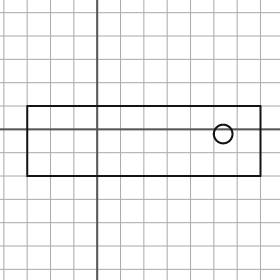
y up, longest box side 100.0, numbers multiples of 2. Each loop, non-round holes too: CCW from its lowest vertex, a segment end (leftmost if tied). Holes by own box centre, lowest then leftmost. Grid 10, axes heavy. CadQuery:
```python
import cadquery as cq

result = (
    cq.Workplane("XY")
    .moveTo(-30.0, -20.0)
    .lineTo(70.0, -20.0)
    .lineTo(70.0, 10.0)
    .lineTo(-30.0, 10.0)
    .close()
    .moveTo(54.0, -2.0)
    .circle(4.0)
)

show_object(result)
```